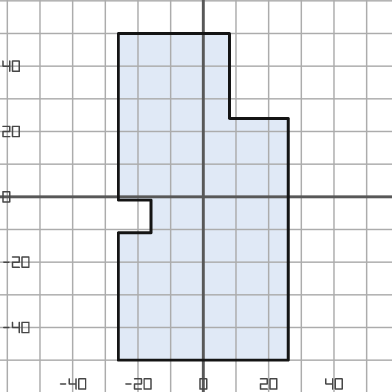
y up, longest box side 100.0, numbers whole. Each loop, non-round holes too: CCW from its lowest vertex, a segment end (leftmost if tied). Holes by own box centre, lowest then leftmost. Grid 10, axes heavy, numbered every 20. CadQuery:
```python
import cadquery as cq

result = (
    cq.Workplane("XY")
    .moveTo(-26.0, -50.0)
    .lineTo(26.0, -50.0)
    .lineTo(26.0, 24.0)
    .lineTo(8.0, 24.0)
    .lineTo(8.0, 50.0)
    .lineTo(-26.0, 50.0)
    .lineTo(-26.0, -1.0)
    .lineTo(-16.0, -1.0)
    .lineTo(-16.0, -11.0)
    .lineTo(-26.0, -11.0)
    .close()
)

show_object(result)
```